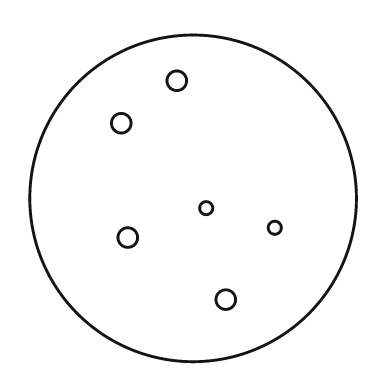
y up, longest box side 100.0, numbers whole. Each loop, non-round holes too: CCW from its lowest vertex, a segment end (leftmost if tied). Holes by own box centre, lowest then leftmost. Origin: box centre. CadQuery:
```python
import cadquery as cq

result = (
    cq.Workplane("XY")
    .moveTo(0.0, 0.0)
    .circle(50.0)
    .moveTo(10.0, -31.0)
    .circle(3.0)
    .moveTo(-20.0, -12.0)
    .circle(3.0)
    .moveTo(25.0, -9.0)
    .circle(2.0)
    .moveTo(4.0, -3.0)
    .circle(2.0)
    .moveTo(-22.0, 23.0)
    .circle(3.0)
    .moveTo(-5.0, 36.0)
    .circle(3.0)
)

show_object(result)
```